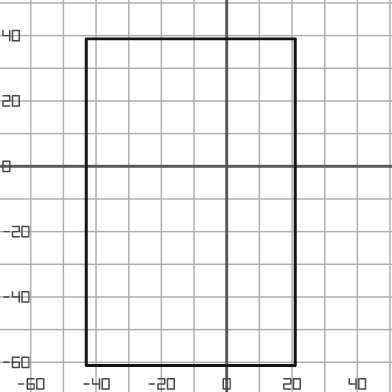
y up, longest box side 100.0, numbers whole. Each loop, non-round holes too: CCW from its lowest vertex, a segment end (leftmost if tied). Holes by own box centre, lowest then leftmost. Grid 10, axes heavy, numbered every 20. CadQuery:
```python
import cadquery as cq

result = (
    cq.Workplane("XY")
    .moveTo(-43.0, -61.0)
    .lineTo(21.0, -61.0)
    .lineTo(21.0, 39.0)
    .lineTo(-43.0, 39.0)
    .close()
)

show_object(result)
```